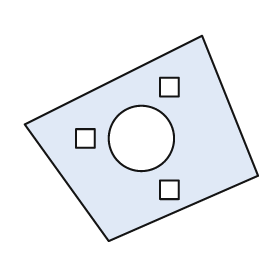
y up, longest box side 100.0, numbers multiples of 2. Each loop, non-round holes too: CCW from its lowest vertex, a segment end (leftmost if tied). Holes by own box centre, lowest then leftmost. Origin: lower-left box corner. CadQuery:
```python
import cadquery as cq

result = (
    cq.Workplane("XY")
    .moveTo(36.0, 0.0)
    .lineTo(100.0, 28.0)
    .lineTo(76.0, 88.0)
    .lineTo(0.0, 50.0)
    .close()
    .moveTo(58.0, 18.0)
    .lineTo(66.0, 18.0)
    .lineTo(66.0, 26.0)
    .lineTo(58.0, 26.0)
    .close()
    .moveTo(22.0, 40.0)
    .lineTo(30.0, 40.0)
    .lineTo(30.0, 48.0)
    .lineTo(22.0, 48.0)
    .close()
    .moveTo(50.0, 44.0)
    .circle(14.0)
    .moveTo(58.0, 62.0)
    .lineTo(66.0, 62.0)
    .lineTo(66.0, 70.0)
    .lineTo(58.0, 70.0)
    .close()
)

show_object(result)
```